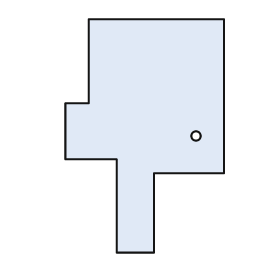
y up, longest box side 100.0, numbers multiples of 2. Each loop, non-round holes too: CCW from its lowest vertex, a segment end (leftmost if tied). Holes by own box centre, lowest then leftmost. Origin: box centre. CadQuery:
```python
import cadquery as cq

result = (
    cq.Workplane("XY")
    .moveTo(-12.0, -50.0)
    .lineTo(4.0, -50.0)
    .lineTo(4.0, -16.0)
    .lineTo(34.0, -16.0)
    .lineTo(34.0, 50.0)
    .lineTo(-24.0, 50.0)
    .lineTo(-24.0, 14.0)
    .lineTo(-34.0, 14.0)
    .lineTo(-34.0, -10.0)
    .lineTo(-12.0, -10.0)
    .close()
    .moveTo(22.0, 0.0)
    .circle(2.0)
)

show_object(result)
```